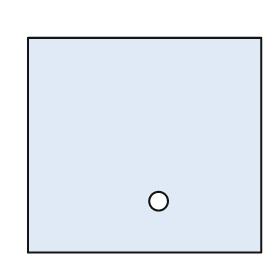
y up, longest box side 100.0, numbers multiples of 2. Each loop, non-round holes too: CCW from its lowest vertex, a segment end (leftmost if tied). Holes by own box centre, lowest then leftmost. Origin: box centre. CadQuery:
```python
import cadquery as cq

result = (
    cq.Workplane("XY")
    .moveTo(-50.0, -46.0)
    .lineTo(50.0, -46.0)
    .lineTo(50.0, 46.0)
    .lineTo(-50.0, 46.0)
    .close()
    .moveTo(6.0, -24.0)
    .circle(4.0)
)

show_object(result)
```